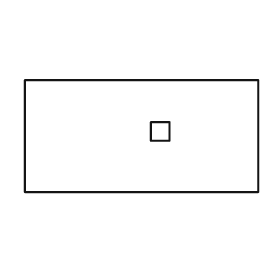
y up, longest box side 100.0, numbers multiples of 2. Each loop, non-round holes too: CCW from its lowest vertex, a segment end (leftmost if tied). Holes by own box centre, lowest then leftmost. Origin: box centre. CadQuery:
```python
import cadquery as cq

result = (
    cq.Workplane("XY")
    .moveTo(-50.0, -24.0)
    .lineTo(50.0, -24.0)
    .lineTo(50.0, 24.0)
    .lineTo(-50.0, 24.0)
    .close()
    .moveTo(4.0, -2.0)
    .lineTo(12.0, -2.0)
    .lineTo(12.0, 6.0)
    .lineTo(4.0, 6.0)
    .close()
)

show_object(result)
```